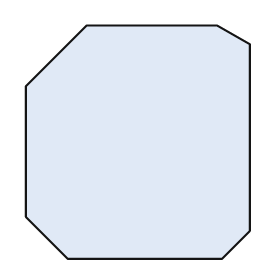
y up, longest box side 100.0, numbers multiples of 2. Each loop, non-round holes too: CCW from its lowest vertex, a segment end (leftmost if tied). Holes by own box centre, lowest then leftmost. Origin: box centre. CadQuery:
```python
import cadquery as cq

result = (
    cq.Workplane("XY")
    .moveTo(-30.0, -50.0)
    .lineTo(36.0, -50.0)
    .lineTo(48.0, -38.0)
    .lineTo(48.0, 42.0)
    .lineTo(34.0, 50.0)
    .lineTo(-22.0, 50.0)
    .lineTo(-48.0, 24.0)
    .lineTo(-48.0, -32.0)
    .close()
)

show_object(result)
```